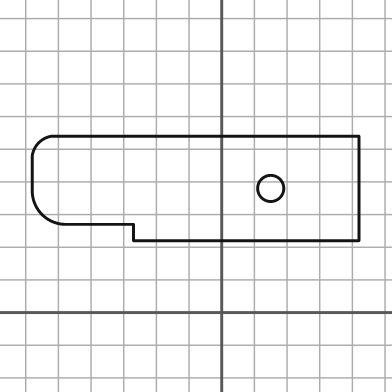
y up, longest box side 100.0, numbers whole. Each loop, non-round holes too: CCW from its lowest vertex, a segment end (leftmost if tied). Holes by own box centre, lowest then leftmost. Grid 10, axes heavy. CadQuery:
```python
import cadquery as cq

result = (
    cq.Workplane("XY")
    .moveTo(-27.0, 22.0)
    .lineTo(42.0, 22.0)
    .lineTo(42.0, 54.0)
    .lineTo(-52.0, 54.0)
    .threePointArc((-56.0, 52.0), (-58.0, 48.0))
    .lineTo(-58.0, 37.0)
    .threePointArc((-55.0, 30.0), (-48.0, 27.0))
    .lineTo(-27.0, 27.0)
    .close()
    .moveTo(15.0, 38.0)
    .circle(4.0)
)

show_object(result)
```